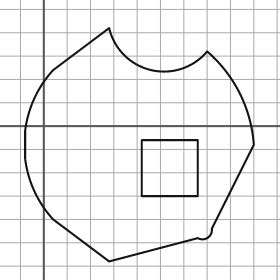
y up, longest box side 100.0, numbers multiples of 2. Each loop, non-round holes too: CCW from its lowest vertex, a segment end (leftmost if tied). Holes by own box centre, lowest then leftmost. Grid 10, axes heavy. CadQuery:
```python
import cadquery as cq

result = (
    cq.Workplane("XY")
    .moveTo(28.0, -58.0)
    .lineTo(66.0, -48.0)
    .threePointArc((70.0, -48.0), (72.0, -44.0))
    .lineTo(90.0, -8.0)
    .threePointArc((84.0, 14.0), (70.0, 32.0))
    .threePointArc((46.0, 24.0), (28.0, 42.0))
    .lineTo(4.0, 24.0)
    .threePointArc((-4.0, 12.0), (-8.0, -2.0))
    .lineTo(-8.0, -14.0)
    .threePointArc((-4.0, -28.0), (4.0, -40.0))
    .close()
    .moveTo(42.0, -30.0)
    .lineTo(66.0, -30.0)
    .lineTo(66.0, -6.0)
    .lineTo(42.0, -6.0)
    .close()
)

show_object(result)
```